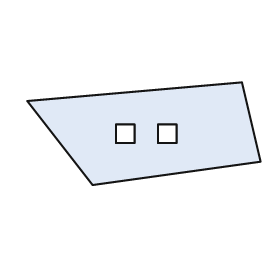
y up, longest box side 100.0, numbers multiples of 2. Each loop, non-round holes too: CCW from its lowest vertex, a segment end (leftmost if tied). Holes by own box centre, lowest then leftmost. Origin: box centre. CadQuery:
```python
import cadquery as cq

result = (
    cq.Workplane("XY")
    .moveTo(-22.0, -22.0)
    .lineTo(50.0, -12.0)
    .lineTo(42.0, 22.0)
    .lineTo(-50.0, 14.0)
    .close()
    .moveTo(-12.0, -4.0)
    .lineTo(-4.0, -4.0)
    .lineTo(-4.0, 4.0)
    .lineTo(-12.0, 4.0)
    .close()
    .moveTo(6.0, -4.0)
    .lineTo(14.0, -4.0)
    .lineTo(14.0, 4.0)
    .lineTo(6.0, 4.0)
    .close()
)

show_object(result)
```